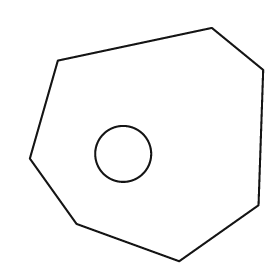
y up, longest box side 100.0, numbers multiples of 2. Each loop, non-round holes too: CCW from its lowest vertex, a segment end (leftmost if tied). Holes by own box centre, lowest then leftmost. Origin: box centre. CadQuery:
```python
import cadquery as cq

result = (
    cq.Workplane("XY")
    .moveTo(14.0, -50.0)
    .lineTo(48.0, -26.0)
    .lineTo(50.0, 32.0)
    .lineTo(28.0, 50.0)
    .lineTo(-38.0, 36.0)
    .lineTo(-50.0, -6.0)
    .lineTo(-30.0, -34.0)
    .close()
    .moveTo(-10.0, -4.0)
    .circle(12.0)
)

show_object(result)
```